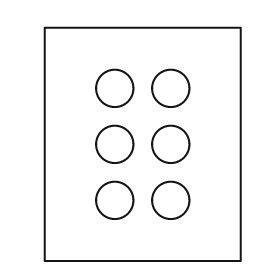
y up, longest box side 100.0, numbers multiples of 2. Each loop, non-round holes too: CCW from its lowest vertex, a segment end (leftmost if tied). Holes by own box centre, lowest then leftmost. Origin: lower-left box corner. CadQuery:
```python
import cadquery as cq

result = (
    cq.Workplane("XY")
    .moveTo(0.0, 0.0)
    .lineTo(84.0, 0.0)
    .lineTo(84.0, 100.0)
    .lineTo(0.0, 100.0)
    .close()
    .moveTo(30.0, 26.0)
    .circle(8.0)
    .moveTo(54.0, 26.0)
    .circle(8.0)
    .moveTo(30.0, 50.0)
    .circle(8.0)
    .moveTo(54.0, 50.0)
    .circle(8.0)
    .moveTo(30.0, 74.0)
    .circle(8.0)
    .moveTo(54.0, 74.0)
    .circle(8.0)
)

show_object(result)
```